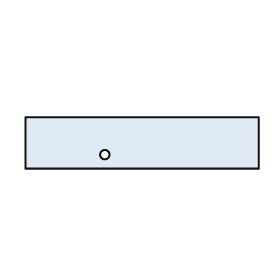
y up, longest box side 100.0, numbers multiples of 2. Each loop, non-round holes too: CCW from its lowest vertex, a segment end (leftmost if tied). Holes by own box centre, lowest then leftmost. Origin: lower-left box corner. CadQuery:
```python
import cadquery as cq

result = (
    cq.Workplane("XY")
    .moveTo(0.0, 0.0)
    .lineTo(100.0, 0.0)
    .lineTo(100.0, 22.0)
    .lineTo(0.0, 22.0)
    .close()
    .moveTo(34.0, 6.0)
    .circle(2.0)
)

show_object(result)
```